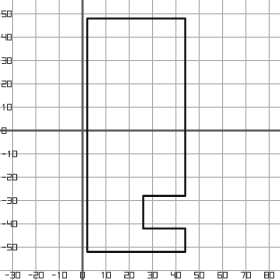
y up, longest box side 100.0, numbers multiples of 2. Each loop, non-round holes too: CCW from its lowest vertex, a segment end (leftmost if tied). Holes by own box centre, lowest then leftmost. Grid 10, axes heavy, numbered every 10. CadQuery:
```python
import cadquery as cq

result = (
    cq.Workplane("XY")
    .moveTo(2.0, -52.0)
    .lineTo(44.0, -52.0)
    .lineTo(44.0, -42.0)
    .lineTo(26.0, -42.0)
    .lineTo(26.0, -28.0)
    .lineTo(44.0, -28.0)
    .lineTo(44.0, 48.0)
    .lineTo(2.0, 48.0)
    .close()
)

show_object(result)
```